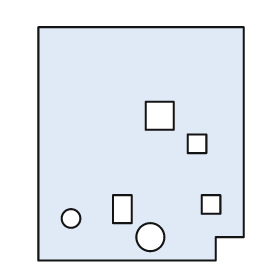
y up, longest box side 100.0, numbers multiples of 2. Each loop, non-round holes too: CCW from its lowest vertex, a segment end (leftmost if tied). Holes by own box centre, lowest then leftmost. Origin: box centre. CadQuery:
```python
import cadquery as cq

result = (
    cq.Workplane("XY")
    .moveTo(-44.0, -50.0)
    .lineTo(32.0, -50.0)
    .lineTo(32.0, -40.0)
    .lineTo(44.0, -40.0)
    .lineTo(44.0, 50.0)
    .lineTo(-44.0, 50.0)
    .close()
    .moveTo(4.0, -40.0)
    .circle(6.0)
    .moveTo(-30.0, -32.0)
    .circle(4.0)
    .moveTo(-12.0, -34.0)
    .lineTo(-4.0, -34.0)
    .lineTo(-4.0, -22.0)
    .lineTo(-12.0, -22.0)
    .close()
    .moveTo(26.0, -30.0)
    .lineTo(34.0, -30.0)
    .lineTo(34.0, -22.0)
    .lineTo(26.0, -22.0)
    .close()
    .moveTo(20.0, -4.0)
    .lineTo(28.0, -4.0)
    .lineTo(28.0, 4.0)
    .lineTo(20.0, 4.0)
    .close()
    .moveTo(2.0, 6.0)
    .lineTo(14.0, 6.0)
    .lineTo(14.0, 18.0)
    .lineTo(2.0, 18.0)
    .close()
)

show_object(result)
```